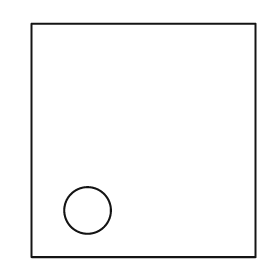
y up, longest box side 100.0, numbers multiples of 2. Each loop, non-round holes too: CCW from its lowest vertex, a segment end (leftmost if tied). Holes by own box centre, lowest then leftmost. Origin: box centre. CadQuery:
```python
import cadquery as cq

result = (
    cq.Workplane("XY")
    .moveTo(-48.0, -50.0)
    .lineTo(48.0, -50.0)
    .lineTo(48.0, 50.0)
    .lineTo(-48.0, 50.0)
    .close()
    .moveTo(-24.0, -30.0)
    .circle(10.0)
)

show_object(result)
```